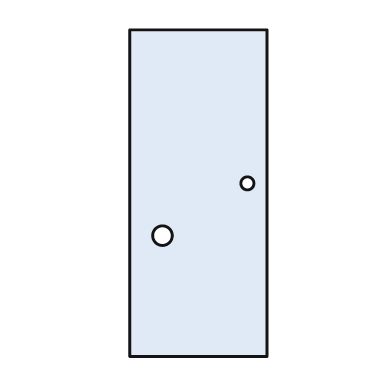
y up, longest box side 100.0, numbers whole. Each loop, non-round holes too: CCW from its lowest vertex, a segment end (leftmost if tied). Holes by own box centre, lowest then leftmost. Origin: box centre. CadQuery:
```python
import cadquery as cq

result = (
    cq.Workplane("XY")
    .moveTo(-21.0, -50.0)
    .lineTo(21.0, -50.0)
    .lineTo(21.0, 50.0)
    .lineTo(-21.0, 50.0)
    .close()
    .moveTo(-11.0, -13.0)
    .circle(3.0)
    .moveTo(15.0, 3.0)
    .circle(2.0)
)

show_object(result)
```